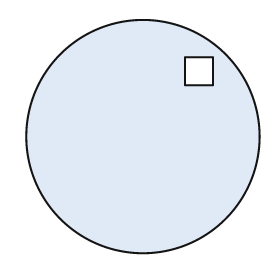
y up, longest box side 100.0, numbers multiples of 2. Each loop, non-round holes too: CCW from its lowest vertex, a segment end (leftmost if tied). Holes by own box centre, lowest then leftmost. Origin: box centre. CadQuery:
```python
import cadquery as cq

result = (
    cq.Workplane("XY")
    .moveTo(0.0, 0.0)
    .circle(50.0)
    .moveTo(18.0, 22.0)
    .lineTo(30.0, 22.0)
    .lineTo(30.0, 34.0)
    .lineTo(18.0, 34.0)
    .close()
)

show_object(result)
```